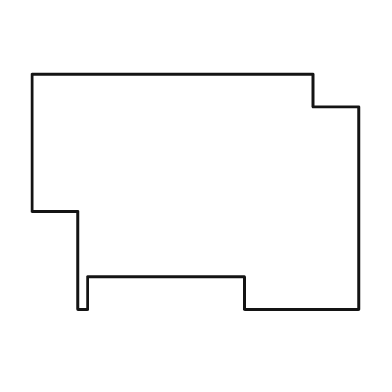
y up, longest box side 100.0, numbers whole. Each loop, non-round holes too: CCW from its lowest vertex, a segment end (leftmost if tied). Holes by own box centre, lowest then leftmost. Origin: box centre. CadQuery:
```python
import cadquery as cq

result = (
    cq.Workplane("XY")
    .moveTo(-36.0, -36.0)
    .lineTo(-33.0, -36.0)
    .lineTo(-33.0, -26.0)
    .lineTo(15.0, -26.0)
    .lineTo(15.0, -36.0)
    .lineTo(50.0, -36.0)
    .lineTo(50.0, 26.0)
    .lineTo(36.0, 26.0)
    .lineTo(36.0, 36.0)
    .lineTo(-50.0, 36.0)
    .lineTo(-50.0, -6.0)
    .lineTo(-36.0, -6.0)
    .close()
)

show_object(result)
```